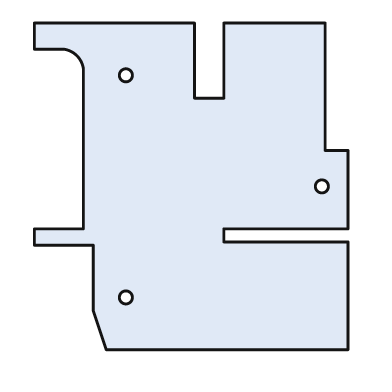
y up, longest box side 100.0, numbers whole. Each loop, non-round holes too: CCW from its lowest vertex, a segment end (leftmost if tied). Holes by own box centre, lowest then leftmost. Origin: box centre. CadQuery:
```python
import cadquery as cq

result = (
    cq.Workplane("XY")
    .moveTo(-26.0, -50.0)
    .lineTo(48.0, -50.0)
    .lineTo(48.0, -17.0)
    .lineTo(10.0, -17.0)
    .lineTo(10.0, -13.0)
    .lineTo(48.0, -13.0)
    .lineTo(48.0, 11.0)
    .lineTo(41.0, 11.0)
    .lineTo(41.0, 50.0)
    .lineTo(10.0, 50.0)
    .lineTo(10.0, 27.0)
    .lineTo(1.0, 27.0)
    .lineTo(1.0, 50.0)
    .lineTo(-48.0, 50.0)
    .lineTo(-48.0, 42.0)
    .lineTo(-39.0, 42.0)
    .threePointArc((-35.0, 40.0), (-33.0, 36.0))
    .lineTo(-33.0, -13.0)
    .lineTo(-48.0, -13.0)
    .lineTo(-48.0, -18.0)
    .lineTo(-30.0, -18.0)
    .lineTo(-30.0, -38.0)
    .close()
    .moveTo(-20.0, -34.0)
    .circle(2.0)
    .moveTo(40.0, 0.0)
    .circle(2.0)
    .moveTo(-20.0, 34.0)
    .circle(2.0)
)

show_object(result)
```